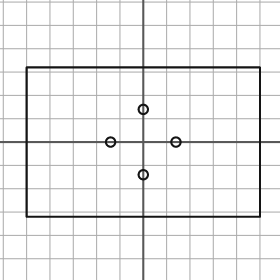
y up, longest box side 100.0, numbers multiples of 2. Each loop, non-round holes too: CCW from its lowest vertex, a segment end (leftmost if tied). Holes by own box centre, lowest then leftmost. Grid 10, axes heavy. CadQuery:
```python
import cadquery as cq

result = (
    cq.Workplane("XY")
    .moveTo(-50.0, -32.0)
    .lineTo(50.0, -32.0)
    .lineTo(50.0, 32.0)
    .lineTo(-50.0, 32.0)
    .close()
    .moveTo(0.0, -14.0)
    .circle(2.0)
    .moveTo(-14.0, 0.0)
    .circle(2.0)
    .moveTo(14.0, 0.0)
    .circle(2.0)
    .moveTo(0.0, 14.0)
    .circle(2.0)
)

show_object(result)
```